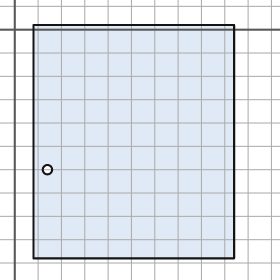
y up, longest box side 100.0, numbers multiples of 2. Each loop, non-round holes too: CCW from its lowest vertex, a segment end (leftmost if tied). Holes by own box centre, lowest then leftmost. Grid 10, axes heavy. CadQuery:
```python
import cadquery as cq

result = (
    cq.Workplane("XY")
    .moveTo(8.0, -98.0)
    .lineTo(94.0, -98.0)
    .lineTo(94.0, 2.0)
    .lineTo(8.0, 2.0)
    .close()
    .moveTo(14.0, -60.0)
    .circle(2.0)
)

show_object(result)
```